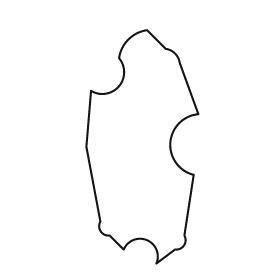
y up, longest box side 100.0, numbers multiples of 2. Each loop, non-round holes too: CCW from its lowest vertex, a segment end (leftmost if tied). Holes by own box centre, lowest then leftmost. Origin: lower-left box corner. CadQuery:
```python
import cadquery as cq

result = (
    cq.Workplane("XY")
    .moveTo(30.0, 0.0)
    .lineTo(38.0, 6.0)
    .threePointArc((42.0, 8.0), (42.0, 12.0))
    .lineTo(46.0, 38.0)
    .threePointArc((36.0, 52.0), (48.0, 64.0))
    .lineTo(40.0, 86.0)
    .threePointArc((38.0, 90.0), (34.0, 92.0))
    .lineTo(26.0, 100.0)
    .threePointArc((18.0, 96.0), (14.0, 88.0))
    .threePointArc((14.0, 76.0), (2.0, 74.0))
    .lineTo(0.0, 50.0)
    .lineTo(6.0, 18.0)
    .threePointArc((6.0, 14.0), (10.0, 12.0))
    .lineTo(16.0, 6.0)
    .threePointArc((26.0, 10.0), (30.0, 0.0))
    .close()
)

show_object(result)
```